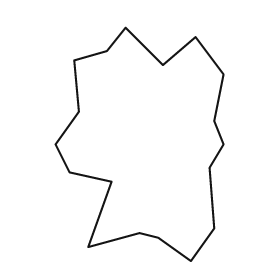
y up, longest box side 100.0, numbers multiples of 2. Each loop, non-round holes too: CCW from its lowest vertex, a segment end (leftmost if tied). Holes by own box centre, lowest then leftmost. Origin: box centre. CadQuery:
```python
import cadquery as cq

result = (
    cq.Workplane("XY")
    .moveTo(22.0, -50.0)
    .lineTo(32.0, -36.0)
    .lineTo(30.0, -10.0)
    .lineTo(36.0, 0.0)
    .lineTo(32.0, 10.0)
    .lineTo(36.0, 30.0)
    .lineTo(24.0, 46.0)
    .lineTo(10.0, 34.0)
    .lineTo(-6.0, 50.0)
    .lineTo(-14.0, 40.0)
    .lineTo(-28.0, 36.0)
    .lineTo(-26.0, 14.0)
    .lineTo(-36.0, 0.0)
    .lineTo(-30.0, -12.0)
    .lineTo(-12.0, -16.0)
    .lineTo(-22.0, -44.0)
    .lineTo(0.0, -38.0)
    .lineTo(8.0, -40.0)
    .close()
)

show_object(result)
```